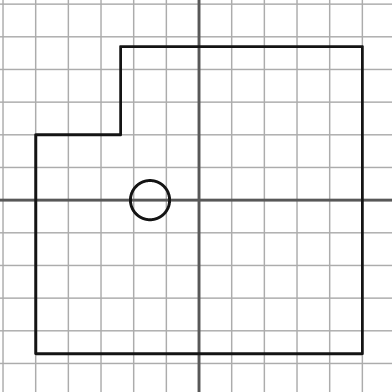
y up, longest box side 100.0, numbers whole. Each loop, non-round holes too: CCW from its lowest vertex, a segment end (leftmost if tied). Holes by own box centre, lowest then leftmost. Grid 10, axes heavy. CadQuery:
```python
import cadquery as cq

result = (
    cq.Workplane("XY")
    .moveTo(-50.0, -47.0)
    .lineTo(50.0, -47.0)
    .lineTo(50.0, 47.0)
    .lineTo(-24.0, 47.0)
    .lineTo(-24.0, 20.0)
    .lineTo(-50.0, 20.0)
    .close()
    .moveTo(-15.0, 0.0)
    .circle(6.0)
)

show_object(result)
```